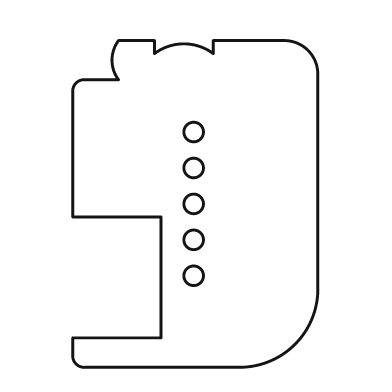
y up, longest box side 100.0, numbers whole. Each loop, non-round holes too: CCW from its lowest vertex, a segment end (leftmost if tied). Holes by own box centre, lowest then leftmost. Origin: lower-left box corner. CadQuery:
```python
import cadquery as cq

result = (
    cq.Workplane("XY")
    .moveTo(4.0, 0.0)
    .lineTo(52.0, 0.0)
    .threePointArc((68.0, 7.0), (75.0, 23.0))
    .lineTo(75.0, 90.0)
    .threePointArc((72.0, 97.0), (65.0, 100.0))
    .lineTo(43.0, 100.0)
    .lineTo(43.0, 96.0)
    .threePointArc((34.0, 99.0), (25.0, 96.0))
    .lineTo(25.0, 100.0)
    .lineTo(14.0, 100.0)
    .threePointArc((12.0, 94.0), (14.0, 88.0))
    .lineTo(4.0, 88.0)
    .threePointArc((1.0, 87.0), (0.0, 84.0))
    .lineTo(0.0, 46.0)
    .lineTo(27.0, 46.0)
    .lineTo(27.0, 9.0)
    .lineTo(0.0, 9.0)
    .lineTo(0.0, 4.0)
    .threePointArc((1.0, 1.0), (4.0, 0.0))
    .close()
    .moveTo(37.0, 28.0)
    .circle(3.0)
    .moveTo(37.0, 39.0)
    .circle(3.0)
    .moveTo(37.0, 50.0)
    .circle(3.0)
    .moveTo(37.0, 61.0)
    .circle(3.0)
    .moveTo(37.0, 72.0)
    .circle(3.0)
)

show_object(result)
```